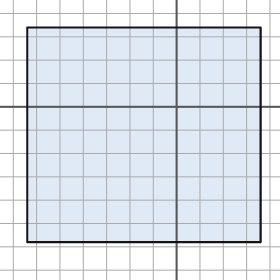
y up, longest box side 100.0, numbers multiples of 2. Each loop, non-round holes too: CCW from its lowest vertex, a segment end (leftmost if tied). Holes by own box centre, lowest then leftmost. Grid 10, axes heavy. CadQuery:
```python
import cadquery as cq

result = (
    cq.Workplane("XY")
    .moveTo(-64.0, -58.0)
    .lineTo(36.0, -58.0)
    .lineTo(36.0, 34.0)
    .lineTo(-64.0, 34.0)
    .close()
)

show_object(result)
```